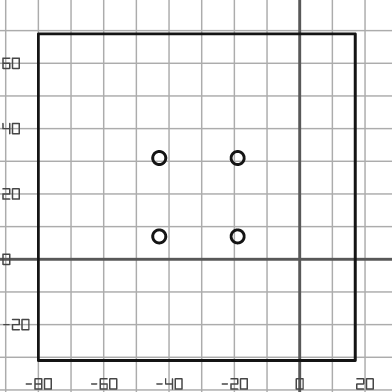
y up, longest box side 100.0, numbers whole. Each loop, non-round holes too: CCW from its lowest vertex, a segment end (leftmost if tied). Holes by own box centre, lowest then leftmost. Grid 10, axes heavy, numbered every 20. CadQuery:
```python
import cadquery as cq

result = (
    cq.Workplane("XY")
    .moveTo(-80.0, -31.0)
    .lineTo(17.0, -31.0)
    .lineTo(17.0, 69.0)
    .lineTo(-80.0, 69.0)
    .close()
    .moveTo(-43.0, 7.0)
    .circle(2.0)
    .moveTo(-19.0, 7.0)
    .circle(2.0)
    .moveTo(-43.0, 31.0)
    .circle(2.0)
    .moveTo(-19.0, 31.0)
    .circle(2.0)
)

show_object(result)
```